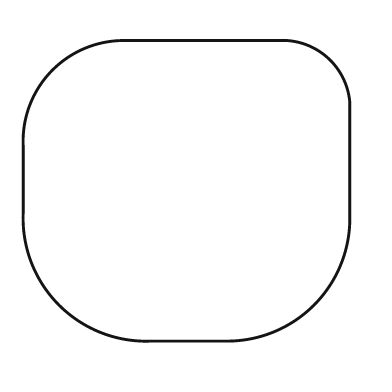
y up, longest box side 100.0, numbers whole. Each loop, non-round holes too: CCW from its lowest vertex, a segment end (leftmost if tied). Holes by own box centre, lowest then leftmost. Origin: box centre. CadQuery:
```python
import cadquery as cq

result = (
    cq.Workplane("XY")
    .moveTo(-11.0, -46.0)
    .lineTo(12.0, -46.0)
    .threePointArc((39.0, -35.0), (50.0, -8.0))
    .lineTo(50.0, 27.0)
    .threePointArc((44.0, 40.0), (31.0, 46.0))
    .lineTo(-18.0, 46.0)
    .threePointArc((-41.0, 37.0), (-50.0, 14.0))
    .lineTo(-50.0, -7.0)
    .threePointArc((-39.0, -35.0), (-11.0, -46.0))
    .close()
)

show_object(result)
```